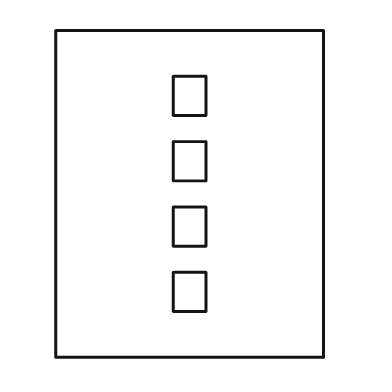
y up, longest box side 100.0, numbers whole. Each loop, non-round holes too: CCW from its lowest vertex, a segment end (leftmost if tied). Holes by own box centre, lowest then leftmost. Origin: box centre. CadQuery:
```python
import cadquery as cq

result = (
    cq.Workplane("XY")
    .moveTo(-41.0, -50.0)
    .lineTo(41.0, -50.0)
    .lineTo(41.0, 50.0)
    .lineTo(-41.0, 50.0)
    .close()
    .moveTo(-5.0, -36.0)
    .lineTo(5.0, -36.0)
    .lineTo(5.0, -24.0)
    .lineTo(-5.0, -24.0)
    .close()
    .moveTo(-5.0, -16.0)
    .lineTo(5.0, -16.0)
    .lineTo(5.0, -4.0)
    .lineTo(-5.0, -4.0)
    .close()
    .moveTo(-5.0, 4.0)
    .lineTo(5.0, 4.0)
    .lineTo(5.0, 16.0)
    .lineTo(-5.0, 16.0)
    .close()
    .moveTo(-5.0, 24.0)
    .lineTo(5.0, 24.0)
    .lineTo(5.0, 36.0)
    .lineTo(-5.0, 36.0)
    .close()
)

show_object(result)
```